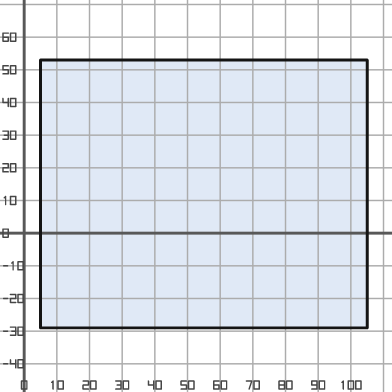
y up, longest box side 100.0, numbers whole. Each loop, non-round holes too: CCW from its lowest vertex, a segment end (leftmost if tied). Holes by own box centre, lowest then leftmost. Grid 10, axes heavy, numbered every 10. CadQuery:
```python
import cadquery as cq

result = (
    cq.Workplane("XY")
    .moveTo(5.0, -29.0)
    .lineTo(105.0, -29.0)
    .lineTo(105.0, 53.0)
    .lineTo(5.0, 53.0)
    .close()
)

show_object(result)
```